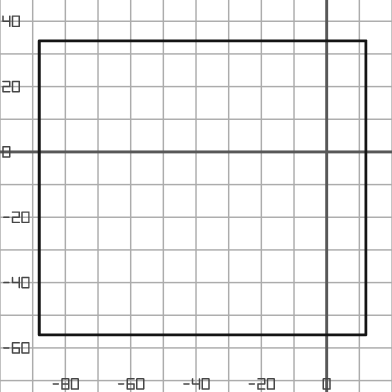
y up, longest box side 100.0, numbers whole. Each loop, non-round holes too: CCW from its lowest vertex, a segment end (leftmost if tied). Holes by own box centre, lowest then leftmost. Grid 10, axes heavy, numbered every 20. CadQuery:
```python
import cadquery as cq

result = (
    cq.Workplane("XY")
    .moveTo(-88.0, -56.0)
    .lineTo(12.0, -56.0)
    .lineTo(12.0, 34.0)
    .lineTo(-88.0, 34.0)
    .close()
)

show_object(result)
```